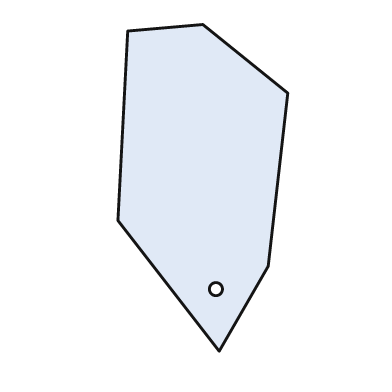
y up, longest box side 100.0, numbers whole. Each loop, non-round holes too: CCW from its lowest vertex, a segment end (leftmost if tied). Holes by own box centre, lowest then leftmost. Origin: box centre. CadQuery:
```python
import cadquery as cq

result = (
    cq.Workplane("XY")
    .moveTo(5.0, -50.0)
    .lineTo(20.0, -24.0)
    .lineTo(26.0, 29.0)
    .lineTo(0.0, 50.0)
    .lineTo(-23.0, 48.0)
    .lineTo(-26.0, -10.0)
    .close()
    .moveTo(4.0, -31.0)
    .circle(2.0)
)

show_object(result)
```